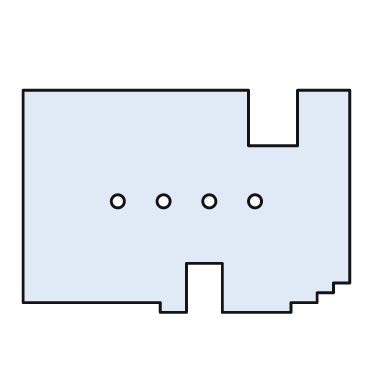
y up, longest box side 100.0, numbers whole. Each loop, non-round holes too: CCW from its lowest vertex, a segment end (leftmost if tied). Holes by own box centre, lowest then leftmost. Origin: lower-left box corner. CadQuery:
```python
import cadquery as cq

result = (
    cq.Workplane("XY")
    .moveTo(42.0, 0.0)
    .lineTo(50.0, 0.0)
    .lineTo(50.0, 15.0)
    .lineTo(61.0, 15.0)
    .lineTo(61.0, 0.0)
    .lineTo(82.0, 0.0)
    .lineTo(82.0, 3.0)
    .lineTo(90.0, 3.0)
    .lineTo(90.0, 6.0)
    .lineTo(95.0, 6.0)
    .lineTo(95.0, 9.0)
    .lineTo(100.0, 9.0)
    .lineTo(100.0, 68.0)
    .lineTo(84.0, 68.0)
    .lineTo(84.0, 51.0)
    .lineTo(69.0, 51.0)
    .lineTo(69.0, 68.0)
    .lineTo(0.0, 68.0)
    .lineTo(0.0, 3.0)
    .lineTo(42.0, 3.0)
    .close()
    .moveTo(29.0, 34.0)
    .circle(2.0)
    .moveTo(43.0, 34.0)
    .circle(2.0)
    .moveTo(57.0, 34.0)
    .circle(2.0)
    .moveTo(71.0, 34.0)
    .circle(2.0)
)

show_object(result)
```